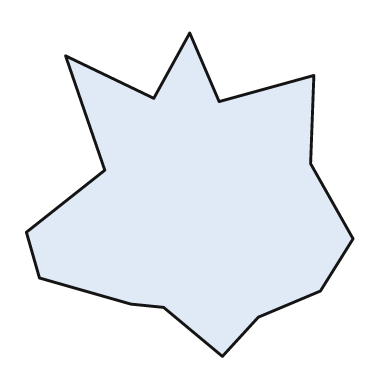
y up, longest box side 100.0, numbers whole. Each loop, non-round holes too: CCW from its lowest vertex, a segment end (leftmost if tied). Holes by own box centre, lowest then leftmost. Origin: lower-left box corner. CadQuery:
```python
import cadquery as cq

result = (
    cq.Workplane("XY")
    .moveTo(60.0, 0.0)
    .lineTo(71.0, 12.0)
    .lineTo(90.0, 20.0)
    .lineTo(100.0, 36.0)
    .lineTo(87.0, 59.0)
    .lineTo(88.0, 86.0)
    .lineTo(59.0, 78.0)
    .lineTo(50.0, 99.0)
    .lineTo(39.0, 79.0)
    .lineTo(12.0, 92.0)
    .lineTo(24.0, 57.0)
    .lineTo(0.0, 38.0)
    .lineTo(4.0, 24.0)
    .lineTo(32.0, 16.0)
    .lineTo(42.0, 15.0)
    .close()
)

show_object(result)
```